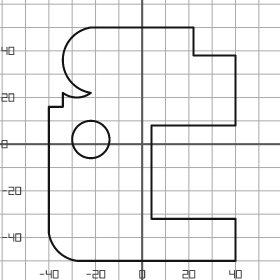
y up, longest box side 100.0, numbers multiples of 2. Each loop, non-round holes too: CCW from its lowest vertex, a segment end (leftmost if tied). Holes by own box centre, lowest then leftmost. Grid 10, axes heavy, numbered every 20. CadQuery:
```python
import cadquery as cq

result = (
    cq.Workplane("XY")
    .moveTo(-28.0, -50.0)
    .lineTo(40.0, -50.0)
    .lineTo(40.0, -32.0)
    .lineTo(4.0, -32.0)
    .lineTo(4.0, 8.0)
    .lineTo(40.0, 8.0)
    .lineTo(40.0, 38.0)
    .lineTo(22.0, 38.0)
    .lineTo(22.0, 50.0)
    .lineTo(-22.0, 50.0)
    .threePointArc((-34.0, 36.0), (-22.0, 22.0))
    .threePointArc((-28.0, 20.0), (-34.0, 22.0))
    .lineTo(-34.0, 16.0)
    .lineTo(-40.0, 16.0)
    .lineTo(-40.0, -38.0)
    .threePointArc((-36.0, -46.0), (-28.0, -50.0))
    .close()
    .moveTo(-22.0, 2.0)
    .circle(8.0)
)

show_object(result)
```